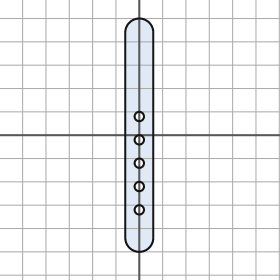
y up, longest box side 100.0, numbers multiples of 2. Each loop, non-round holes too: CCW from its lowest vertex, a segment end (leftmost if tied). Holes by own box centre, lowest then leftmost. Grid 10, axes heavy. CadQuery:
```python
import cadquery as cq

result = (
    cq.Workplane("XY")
    .moveTo(-6.0, -44.0)
    .threePointArc((0.0, -50.0), (6.0, -44.0))
    .lineTo(6.0, 44.0)
    .threePointArc((0.0, 50.0), (-6.0, 44.0))
    .close()
    .moveTo(0.0, -32.0)
    .circle(2.0)
    .moveTo(0.0, -22.0)
    .circle(2.0)
    .moveTo(0.0, -12.0)
    .circle(2.0)
    .moveTo(0.0, -2.0)
    .circle(2.0)
    .moveTo(0.0, 8.0)
    .circle(2.0)
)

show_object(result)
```